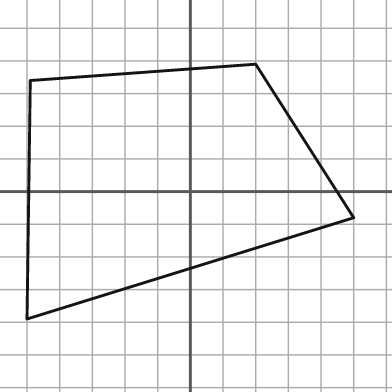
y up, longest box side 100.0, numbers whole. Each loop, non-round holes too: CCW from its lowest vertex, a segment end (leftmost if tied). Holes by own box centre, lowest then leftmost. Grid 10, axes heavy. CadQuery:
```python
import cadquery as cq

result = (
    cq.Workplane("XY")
    .moveTo(-50.0, -39.0)
    .lineTo(50.0, -8.0)
    .lineTo(20.0, 39.0)
    .lineTo(-49.0, 34.0)
    .close()
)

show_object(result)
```